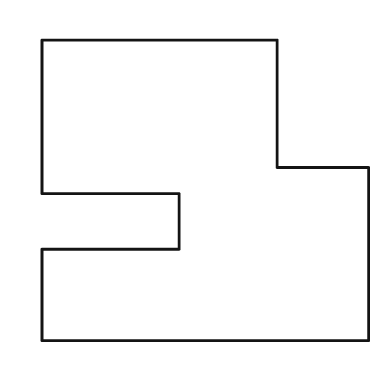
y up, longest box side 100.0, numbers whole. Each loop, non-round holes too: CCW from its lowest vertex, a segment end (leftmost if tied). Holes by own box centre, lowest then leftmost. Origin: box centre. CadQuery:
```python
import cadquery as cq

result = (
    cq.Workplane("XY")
    .moveTo(-50.0, -46.0)
    .lineTo(50.0, -46.0)
    .lineTo(50.0, 7.0)
    .lineTo(22.0, 7.0)
    .lineTo(22.0, 46.0)
    .lineTo(-50.0, 46.0)
    .lineTo(-50.0, -1.0)
    .lineTo(-8.0, -1.0)
    .lineTo(-8.0, -18.0)
    .lineTo(-50.0, -18.0)
    .close()
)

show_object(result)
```